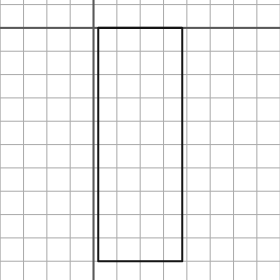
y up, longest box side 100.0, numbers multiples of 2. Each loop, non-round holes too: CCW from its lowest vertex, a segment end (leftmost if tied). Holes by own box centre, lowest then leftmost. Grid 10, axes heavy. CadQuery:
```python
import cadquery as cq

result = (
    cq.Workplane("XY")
    .moveTo(2.0, -100.0)
    .lineTo(38.0, -100.0)
    .lineTo(38.0, 0.0)
    .lineTo(2.0, 0.0)
    .close()
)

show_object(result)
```